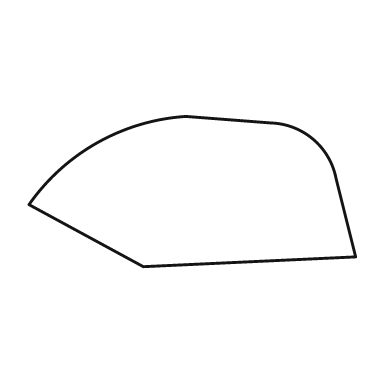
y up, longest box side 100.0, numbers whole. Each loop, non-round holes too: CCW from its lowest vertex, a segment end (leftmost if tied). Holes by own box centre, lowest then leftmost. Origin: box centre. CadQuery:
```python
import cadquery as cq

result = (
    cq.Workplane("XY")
    .moveTo(-15.0, -23.0)
    .lineTo(50.0, -20.0)
    .lineTo(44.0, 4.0)
    .threePointArc((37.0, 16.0), (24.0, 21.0))
    .lineTo(-2.0, 23.0)
    .threePointArc((-29.0, 15.0), (-50.0, -4.0))
    .close()
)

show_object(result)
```